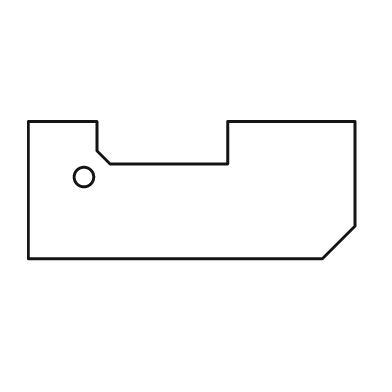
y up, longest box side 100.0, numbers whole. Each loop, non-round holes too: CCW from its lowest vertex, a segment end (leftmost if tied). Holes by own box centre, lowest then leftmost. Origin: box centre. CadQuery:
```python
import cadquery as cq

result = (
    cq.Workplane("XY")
    .moveTo(-50.0, -21.0)
    .lineTo(40.0, -21.0)
    .lineTo(50.0, -11.0)
    .lineTo(50.0, 21.0)
    .lineTo(11.0, 21.0)
    .lineTo(11.0, 8.0)
    .lineTo(-25.0, 8.0)
    .lineTo(-29.0, 12.0)
    .lineTo(-29.0, 21.0)
    .lineTo(-50.0, 21.0)
    .close()
    .moveTo(-33.0, 4.0)
    .circle(3.0)
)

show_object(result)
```